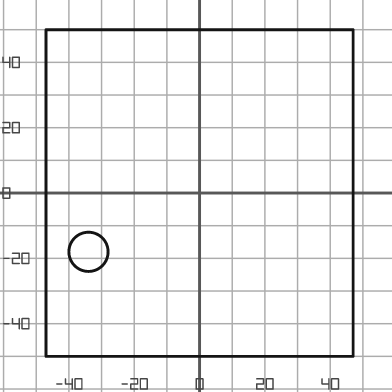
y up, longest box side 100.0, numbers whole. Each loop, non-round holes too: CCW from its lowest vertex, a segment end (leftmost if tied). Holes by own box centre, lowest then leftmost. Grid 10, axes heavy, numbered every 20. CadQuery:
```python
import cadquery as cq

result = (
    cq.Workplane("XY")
    .moveTo(-47.0, -50.0)
    .lineTo(47.0, -50.0)
    .lineTo(47.0, 50.0)
    .lineTo(-47.0, 50.0)
    .close()
    .moveTo(-34.0, -18.0)
    .circle(6.0)
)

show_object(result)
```